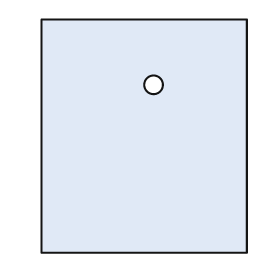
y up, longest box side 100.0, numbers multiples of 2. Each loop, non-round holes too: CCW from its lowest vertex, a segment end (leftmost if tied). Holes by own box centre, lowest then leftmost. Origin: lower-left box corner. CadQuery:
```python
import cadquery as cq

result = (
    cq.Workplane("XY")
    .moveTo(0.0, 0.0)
    .lineTo(88.0, 0.0)
    .lineTo(88.0, 100.0)
    .lineTo(0.0, 100.0)
    .close()
    .moveTo(48.0, 72.0)
    .circle(4.0)
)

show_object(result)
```